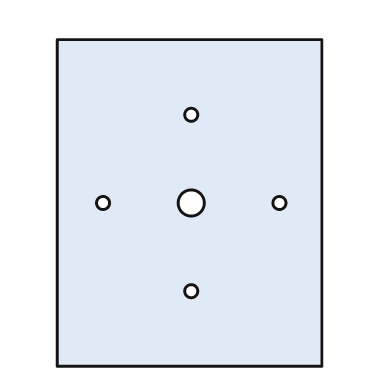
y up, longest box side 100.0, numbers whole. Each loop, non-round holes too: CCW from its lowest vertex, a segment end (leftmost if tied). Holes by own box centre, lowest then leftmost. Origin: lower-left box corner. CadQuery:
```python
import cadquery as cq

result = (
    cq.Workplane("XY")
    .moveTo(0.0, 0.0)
    .lineTo(81.0, 0.0)
    .lineTo(81.0, 100.0)
    .lineTo(0.0, 100.0)
    .close()
    .moveTo(41.0, 23.0)
    .circle(2.0)
    .moveTo(14.0, 50.0)
    .circle(2.0)
    .moveTo(41.0, 50.0)
    .circle(4.0)
    .moveTo(68.0, 50.0)
    .circle(2.0)
    .moveTo(41.0, 77.0)
    .circle(2.0)
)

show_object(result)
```